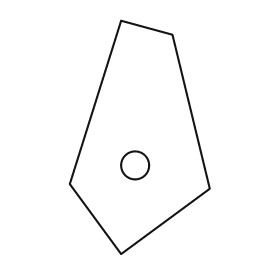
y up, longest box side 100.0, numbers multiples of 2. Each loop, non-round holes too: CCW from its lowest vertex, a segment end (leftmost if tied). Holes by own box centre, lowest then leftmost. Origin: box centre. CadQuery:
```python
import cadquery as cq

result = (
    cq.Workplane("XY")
    .moveTo(-8.0, -50.0)
    .lineTo(30.0, -22.0)
    .lineTo(14.0, 44.0)
    .lineTo(-8.0, 50.0)
    .lineTo(-30.0, -20.0)
    .close()
    .moveTo(-2.0, -12.0)
    .circle(6.0)
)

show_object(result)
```